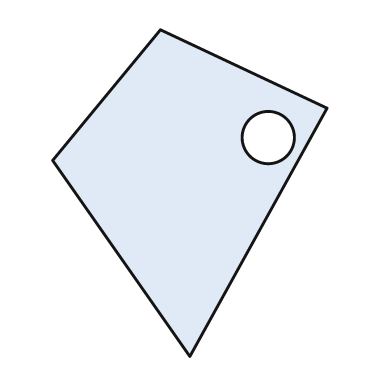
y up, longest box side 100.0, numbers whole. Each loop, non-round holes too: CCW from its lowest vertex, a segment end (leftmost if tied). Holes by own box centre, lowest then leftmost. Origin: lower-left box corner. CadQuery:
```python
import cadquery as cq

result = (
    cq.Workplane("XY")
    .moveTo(42.0, 0.0)
    .lineTo(84.0, 76.0)
    .lineTo(33.0, 100.0)
    .lineTo(0.0, 60.0)
    .close()
    .moveTo(66.0, 67.0)
    .circle(8.0)
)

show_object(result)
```